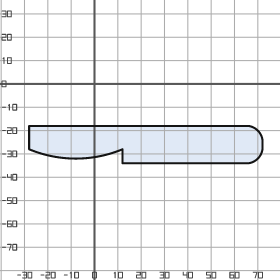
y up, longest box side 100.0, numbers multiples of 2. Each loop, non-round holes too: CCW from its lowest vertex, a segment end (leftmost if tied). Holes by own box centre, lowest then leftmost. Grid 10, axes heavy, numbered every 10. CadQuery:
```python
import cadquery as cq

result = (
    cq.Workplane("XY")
    .moveTo(12.0, -34.0)
    .lineTo(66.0, -34.0)
    .threePointArc((70.0, -32.0), (72.0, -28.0))
    .lineTo(72.0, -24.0)
    .threePointArc((70.0, -20.0), (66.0, -18.0))
    .lineTo(-28.0, -18.0)
    .lineTo(-28.0, -28.0)
    .threePointArc((-8.0, -32.0), (12.0, -28.0))
    .close()
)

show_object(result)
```